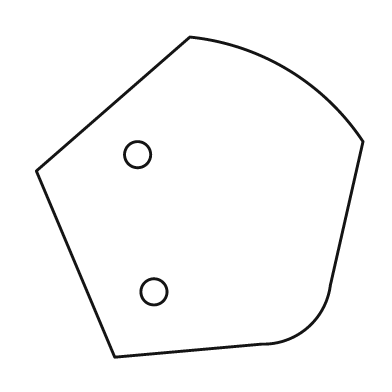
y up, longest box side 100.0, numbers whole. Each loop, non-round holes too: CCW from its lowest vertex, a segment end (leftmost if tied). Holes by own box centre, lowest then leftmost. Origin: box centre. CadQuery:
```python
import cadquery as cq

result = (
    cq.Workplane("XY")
    .moveTo(-26.0, -49.0)
    .lineTo(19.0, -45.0)
    .threePointArc((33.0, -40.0), (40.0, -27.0))
    .lineTo(50.0, 17.0)
    .threePointArc((27.0, 39.0), (-3.0, 49.0))
    .lineTo(-50.0, 8.0)
    .close()
    .moveTo(-14.0, -29.0)
    .circle(4.0)
    .moveTo(-19.0, 13.0)
    .circle(4.0)
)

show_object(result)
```